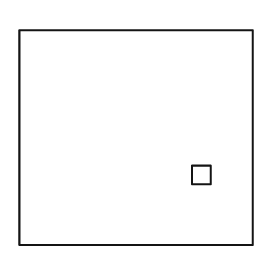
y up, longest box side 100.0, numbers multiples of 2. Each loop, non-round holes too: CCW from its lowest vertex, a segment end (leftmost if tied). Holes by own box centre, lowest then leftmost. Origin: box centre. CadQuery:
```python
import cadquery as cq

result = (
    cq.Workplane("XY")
    .moveTo(-50.0, -46.0)
    .lineTo(50.0, -46.0)
    .lineTo(50.0, 46.0)
    .lineTo(-50.0, 46.0)
    .close()
    .moveTo(24.0, -20.0)
    .lineTo(32.0, -20.0)
    .lineTo(32.0, -12.0)
    .lineTo(24.0, -12.0)
    .close()
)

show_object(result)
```